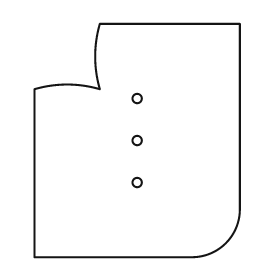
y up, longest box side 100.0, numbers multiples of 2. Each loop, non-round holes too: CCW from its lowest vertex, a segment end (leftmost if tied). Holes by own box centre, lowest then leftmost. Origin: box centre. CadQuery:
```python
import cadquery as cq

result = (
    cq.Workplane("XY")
    .moveTo(-44.0, -50.0)
    .lineTo(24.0, -50.0)
    .threePointArc((38.0, -44.0), (44.0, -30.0))
    .lineTo(44.0, 50.0)
    .lineTo(-16.0, 50.0)
    .threePointArc((-18.0, 36.0), (-16.0, 22.0))
    .threePointArc((-30.0, 24.0), (-44.0, 22.0))
    .close()
    .moveTo(0.0, -18.0)
    .circle(2.0)
    .moveTo(0.0, 0.0)
    .circle(2.0)
    .moveTo(0.0, 18.0)
    .circle(2.0)
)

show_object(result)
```